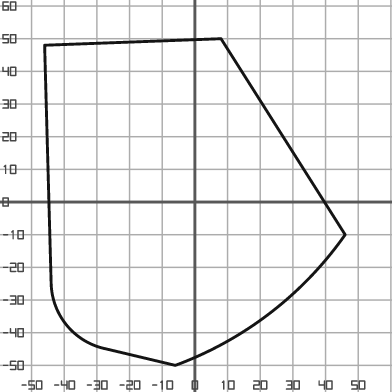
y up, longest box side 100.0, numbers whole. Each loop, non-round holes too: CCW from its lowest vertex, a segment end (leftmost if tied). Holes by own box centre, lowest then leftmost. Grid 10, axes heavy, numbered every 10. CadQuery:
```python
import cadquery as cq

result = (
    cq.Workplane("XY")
    .moveTo(-6.0, -50.0)
    .threePointArc((23.0, -34.0), (46.0, -10.0))
    .lineTo(8.0, 50.0)
    .lineTo(-46.0, 48.0)
    .lineTo(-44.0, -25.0)
    .threePointArc((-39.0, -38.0), (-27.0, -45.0))
    .close()
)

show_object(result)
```